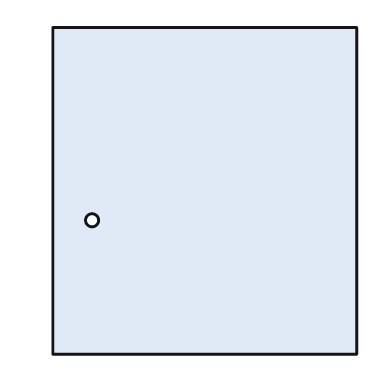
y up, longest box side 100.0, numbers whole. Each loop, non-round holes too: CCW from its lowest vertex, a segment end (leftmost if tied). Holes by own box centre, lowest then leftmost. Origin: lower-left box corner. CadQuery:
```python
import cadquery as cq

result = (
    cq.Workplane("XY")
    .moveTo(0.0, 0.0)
    .lineTo(93.0, 0.0)
    .lineTo(93.0, 100.0)
    .lineTo(0.0, 100.0)
    .close()
    .moveTo(12.0, 41.0)
    .circle(2.0)
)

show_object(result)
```